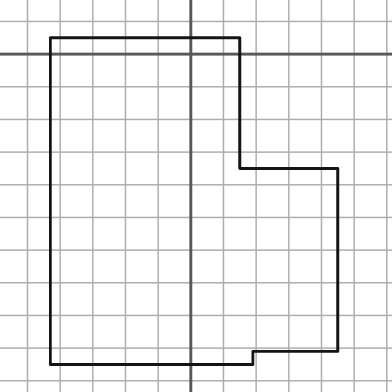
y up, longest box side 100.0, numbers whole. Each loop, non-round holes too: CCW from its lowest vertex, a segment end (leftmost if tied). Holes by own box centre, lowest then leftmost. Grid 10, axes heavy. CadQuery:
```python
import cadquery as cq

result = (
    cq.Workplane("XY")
    .moveTo(-43.0, -95.0)
    .lineTo(19.0, -95.0)
    .lineTo(19.0, -91.0)
    .lineTo(45.0, -91.0)
    .lineTo(45.0, -35.0)
    .lineTo(15.0, -35.0)
    .lineTo(15.0, 5.0)
    .lineTo(-43.0, 5.0)
    .close()
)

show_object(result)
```